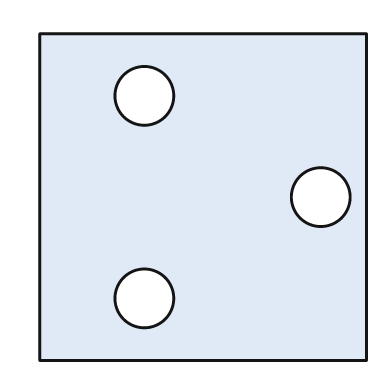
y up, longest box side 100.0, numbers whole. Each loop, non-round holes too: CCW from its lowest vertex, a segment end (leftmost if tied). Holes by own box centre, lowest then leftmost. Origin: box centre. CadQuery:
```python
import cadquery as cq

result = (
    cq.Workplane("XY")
    .moveTo(-50.0, -50.0)
    .lineTo(50.0, -50.0)
    .lineTo(50.0, 50.0)
    .lineTo(-50.0, 50.0)
    .close()
    .moveTo(-18.0, -31.0)
    .circle(9.0)
    .moveTo(36.0, 0.0)
    .circle(9.0)
    .moveTo(-18.0, 31.0)
    .circle(9.0)
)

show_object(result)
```